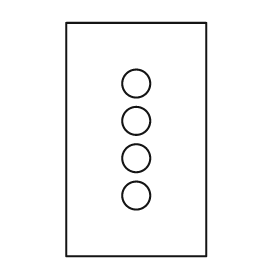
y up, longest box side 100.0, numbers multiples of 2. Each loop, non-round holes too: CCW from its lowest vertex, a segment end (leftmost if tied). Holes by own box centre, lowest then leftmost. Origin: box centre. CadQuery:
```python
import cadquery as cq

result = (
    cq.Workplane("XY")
    .moveTo(-30.0, -50.0)
    .lineTo(30.0, -50.0)
    .lineTo(30.0, 50.0)
    .lineTo(-30.0, 50.0)
    .close()
    .moveTo(0.0, -24.0)
    .circle(6.0)
    .moveTo(0.0, -8.0)
    .circle(6.0)
    .moveTo(0.0, 8.0)
    .circle(6.0)
    .moveTo(0.0, 24.0)
    .circle(6.0)
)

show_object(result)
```